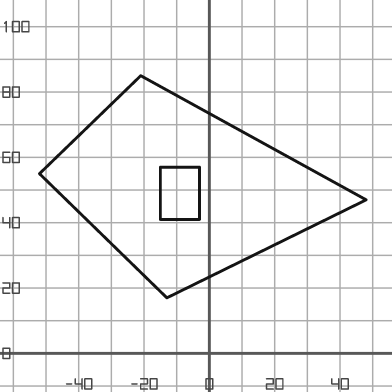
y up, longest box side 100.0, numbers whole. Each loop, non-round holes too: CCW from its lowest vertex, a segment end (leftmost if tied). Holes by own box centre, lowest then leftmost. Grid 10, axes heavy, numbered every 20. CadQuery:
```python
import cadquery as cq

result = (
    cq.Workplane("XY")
    .moveTo(-13.0, 17.0)
    .lineTo(48.0, 47.0)
    .lineTo(-21.0, 85.0)
    .lineTo(-52.0, 55.0)
    .close()
    .moveTo(-15.0, 41.0)
    .lineTo(-3.0, 41.0)
    .lineTo(-3.0, 57.0)
    .lineTo(-15.0, 57.0)
    .close()
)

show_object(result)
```